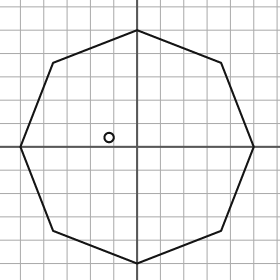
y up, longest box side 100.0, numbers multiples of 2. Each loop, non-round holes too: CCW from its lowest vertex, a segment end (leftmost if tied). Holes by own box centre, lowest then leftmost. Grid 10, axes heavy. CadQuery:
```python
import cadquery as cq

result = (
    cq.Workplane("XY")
    .moveTo(0.0, -50.0)
    .lineTo(36.0, -36.0)
    .lineTo(50.0, 0.0)
    .lineTo(36.0, 36.0)
    .lineTo(0.0, 50.0)
    .lineTo(-36.0, 36.0)
    .lineTo(-50.0, 0.0)
    .lineTo(-36.0, -36.0)
    .close()
    .moveTo(-12.0, 4.0)
    .circle(2.0)
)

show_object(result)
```